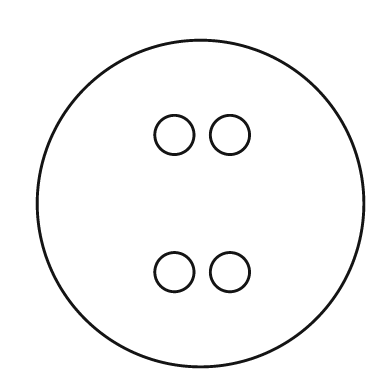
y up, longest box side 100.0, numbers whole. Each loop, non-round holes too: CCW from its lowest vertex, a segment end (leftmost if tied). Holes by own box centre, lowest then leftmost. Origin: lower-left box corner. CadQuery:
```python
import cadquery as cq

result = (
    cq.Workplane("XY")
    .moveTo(50.0, 50.0)
    .circle(50.0)
    .moveTo(42.0, 29.0)
    .circle(6.0)
    .moveTo(59.0, 29.0)
    .circle(6.0)
    .moveTo(42.0, 71.0)
    .circle(6.0)
    .moveTo(59.0, 71.0)
    .circle(6.0)
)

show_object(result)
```